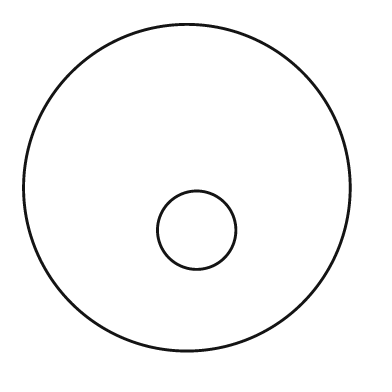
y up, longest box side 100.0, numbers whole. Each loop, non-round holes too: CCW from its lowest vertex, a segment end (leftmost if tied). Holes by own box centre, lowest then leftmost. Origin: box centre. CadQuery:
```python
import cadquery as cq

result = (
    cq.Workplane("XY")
    .moveTo(0.0, 0.0)
    .circle(50.0)
    .moveTo(3.0, -13.0)
    .circle(12.0)
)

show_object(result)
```